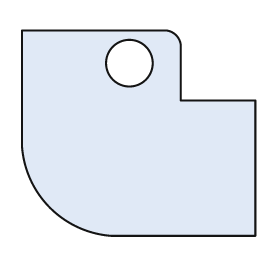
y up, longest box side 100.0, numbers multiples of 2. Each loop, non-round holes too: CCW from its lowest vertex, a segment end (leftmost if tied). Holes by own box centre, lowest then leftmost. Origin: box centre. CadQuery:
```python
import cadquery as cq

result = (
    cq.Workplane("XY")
    .moveTo(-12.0, -44.0)
    .lineTo(50.0, -44.0)
    .lineTo(50.0, 14.0)
    .lineTo(18.0, 14.0)
    .lineTo(18.0, 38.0)
    .threePointArc((16.0, 42.0), (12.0, 44.0))
    .lineTo(-50.0, 44.0)
    .lineTo(-50.0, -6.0)
    .threePointArc((-38.0, -32.0), (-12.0, -44.0))
    .close()
    .moveTo(-4.0, 30.0)
    .circle(10.0)
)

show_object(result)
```